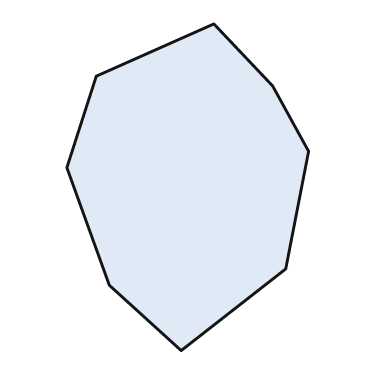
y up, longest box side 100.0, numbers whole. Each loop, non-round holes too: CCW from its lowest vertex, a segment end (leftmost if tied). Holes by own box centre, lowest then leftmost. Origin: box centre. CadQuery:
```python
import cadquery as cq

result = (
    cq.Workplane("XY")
    .moveTo(-2.0, -50.0)
    .lineTo(30.0, -25.0)
    .lineTo(37.0, 11.0)
    .lineTo(26.0, 31.0)
    .lineTo(8.0, 50.0)
    .lineTo(-28.0, 34.0)
    .lineTo(-37.0, 6.0)
    .lineTo(-24.0, -30.0)
    .close()
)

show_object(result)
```